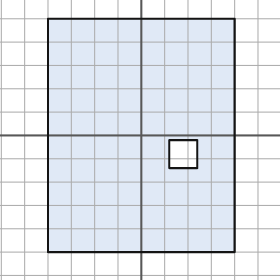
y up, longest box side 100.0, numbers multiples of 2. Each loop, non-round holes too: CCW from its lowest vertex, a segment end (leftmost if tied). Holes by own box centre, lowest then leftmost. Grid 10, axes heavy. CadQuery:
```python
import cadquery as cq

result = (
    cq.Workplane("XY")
    .moveTo(-40.0, -50.0)
    .lineTo(40.0, -50.0)
    .lineTo(40.0, 50.0)
    .lineTo(-40.0, 50.0)
    .close()
    .moveTo(12.0, -14.0)
    .lineTo(24.0, -14.0)
    .lineTo(24.0, -2.0)
    .lineTo(12.0, -2.0)
    .close()
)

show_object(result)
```